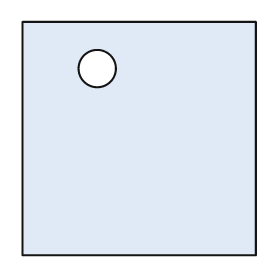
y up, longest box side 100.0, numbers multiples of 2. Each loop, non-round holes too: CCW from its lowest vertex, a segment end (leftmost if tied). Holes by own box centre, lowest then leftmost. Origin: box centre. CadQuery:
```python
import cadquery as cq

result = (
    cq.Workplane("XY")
    .moveTo(-50.0, -50.0)
    .lineTo(50.0, -50.0)
    .lineTo(50.0, 50.0)
    .lineTo(-50.0, 50.0)
    .close()
    .moveTo(-18.0, 30.0)
    .circle(8.0)
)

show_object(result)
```